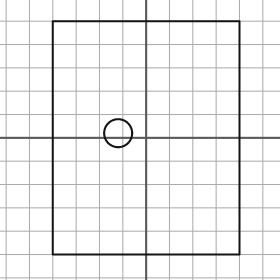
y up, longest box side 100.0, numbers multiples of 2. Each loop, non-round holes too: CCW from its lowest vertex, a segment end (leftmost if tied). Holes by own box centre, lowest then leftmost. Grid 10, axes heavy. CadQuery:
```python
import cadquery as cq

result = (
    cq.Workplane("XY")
    .moveTo(-40.0, -50.0)
    .lineTo(40.0, -50.0)
    .lineTo(40.0, 50.0)
    .lineTo(-40.0, 50.0)
    .close()
    .moveTo(-12.0, 2.0)
    .circle(6.0)
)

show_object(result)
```